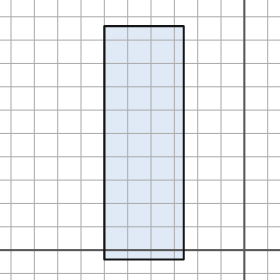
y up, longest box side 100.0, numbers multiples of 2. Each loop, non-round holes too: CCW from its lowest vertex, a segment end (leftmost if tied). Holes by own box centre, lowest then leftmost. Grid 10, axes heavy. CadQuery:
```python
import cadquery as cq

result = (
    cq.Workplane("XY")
    .moveTo(-60.0, -4.0)
    .lineTo(-26.0, -4.0)
    .lineTo(-26.0, 96.0)
    .lineTo(-60.0, 96.0)
    .close()
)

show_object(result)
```